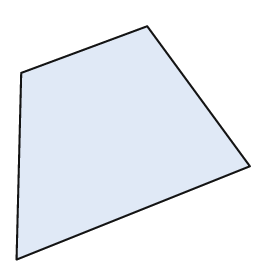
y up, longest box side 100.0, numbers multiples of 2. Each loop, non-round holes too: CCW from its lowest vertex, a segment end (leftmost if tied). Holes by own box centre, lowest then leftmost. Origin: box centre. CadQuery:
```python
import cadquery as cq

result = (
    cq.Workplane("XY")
    .moveTo(-50.0, -50.0)
    .lineTo(50.0, -10.0)
    .lineTo(6.0, 50.0)
    .lineTo(-48.0, 30.0)
    .close()
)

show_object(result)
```